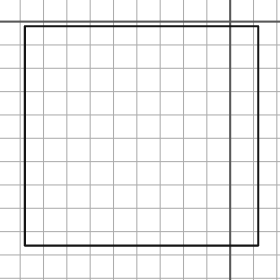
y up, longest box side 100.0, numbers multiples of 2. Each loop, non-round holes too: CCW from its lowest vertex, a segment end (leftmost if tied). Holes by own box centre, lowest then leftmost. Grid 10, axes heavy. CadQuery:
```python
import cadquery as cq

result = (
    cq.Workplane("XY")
    .moveTo(-88.0, -96.0)
    .lineTo(12.0, -96.0)
    .lineTo(12.0, -2.0)
    .lineTo(-88.0, -2.0)
    .close()
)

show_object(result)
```